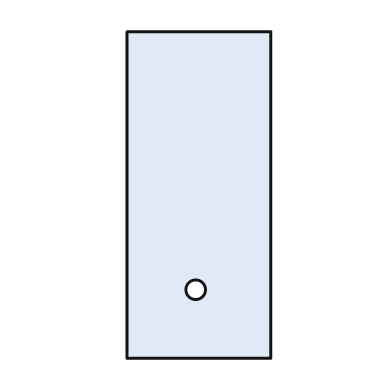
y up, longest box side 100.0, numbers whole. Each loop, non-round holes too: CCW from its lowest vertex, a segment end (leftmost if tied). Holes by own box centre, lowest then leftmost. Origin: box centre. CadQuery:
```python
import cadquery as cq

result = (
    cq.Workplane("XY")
    .moveTo(-22.0, -50.0)
    .lineTo(22.0, -50.0)
    .lineTo(22.0, 50.0)
    .lineTo(-22.0, 50.0)
    .close()
    .moveTo(-1.0, -29.0)
    .circle(3.0)
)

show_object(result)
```